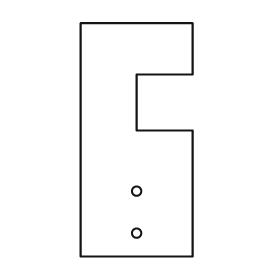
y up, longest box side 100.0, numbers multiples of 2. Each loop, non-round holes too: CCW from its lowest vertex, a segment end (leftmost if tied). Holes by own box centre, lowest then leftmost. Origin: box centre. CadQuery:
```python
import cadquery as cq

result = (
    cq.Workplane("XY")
    .moveTo(-24.0, -50.0)
    .lineTo(24.0, -50.0)
    .lineTo(24.0, 4.0)
    .lineTo(0.0, 4.0)
    .lineTo(0.0, 28.0)
    .lineTo(24.0, 28.0)
    .lineTo(24.0, 50.0)
    .lineTo(-24.0, 50.0)
    .close()
    .moveTo(0.0, -40.0)
    .circle(2.0)
    .moveTo(0.0, -22.0)
    .circle(2.0)
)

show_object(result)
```